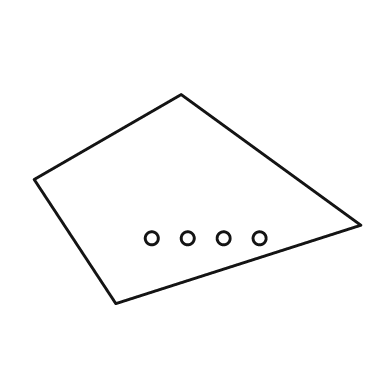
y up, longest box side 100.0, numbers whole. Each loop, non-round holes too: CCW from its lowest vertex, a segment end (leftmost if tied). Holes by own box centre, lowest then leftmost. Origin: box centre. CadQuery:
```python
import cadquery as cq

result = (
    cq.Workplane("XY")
    .moveTo(-25.0, -32.0)
    .lineTo(50.0, -8.0)
    .lineTo(-5.0, 32.0)
    .lineTo(-50.0, 6.0)
    .close()
    .moveTo(-14.0, -12.0)
    .circle(2.0)
    .moveTo(-3.0, -12.0)
    .circle(2.0)
    .moveTo(8.0, -12.0)
    .circle(2.0)
    .moveTo(19.0, -12.0)
    .circle(2.0)
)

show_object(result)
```